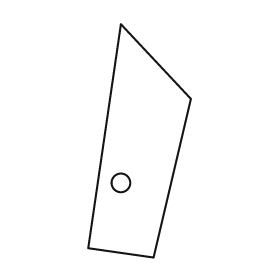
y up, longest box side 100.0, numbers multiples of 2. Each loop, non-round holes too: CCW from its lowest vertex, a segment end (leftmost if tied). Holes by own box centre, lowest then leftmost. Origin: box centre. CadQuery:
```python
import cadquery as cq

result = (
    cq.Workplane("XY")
    .moveTo(6.0, -50.0)
    .lineTo(22.0, 18.0)
    .lineTo(-8.0, 50.0)
    .lineTo(-22.0, -46.0)
    .close()
    .moveTo(-8.0, -18.0)
    .circle(4.0)
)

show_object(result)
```